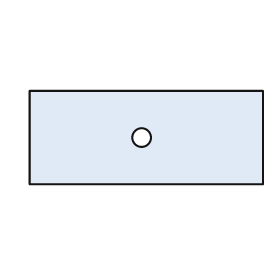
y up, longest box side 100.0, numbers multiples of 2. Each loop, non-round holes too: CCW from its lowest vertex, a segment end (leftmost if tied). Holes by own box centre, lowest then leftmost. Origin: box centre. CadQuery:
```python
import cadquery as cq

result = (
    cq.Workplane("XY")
    .moveTo(-50.0, -20.0)
    .lineTo(50.0, -20.0)
    .lineTo(50.0, 20.0)
    .lineTo(-50.0, 20.0)
    .close()
    .moveTo(-2.0, 0.0)
    .circle(4.0)
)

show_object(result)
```